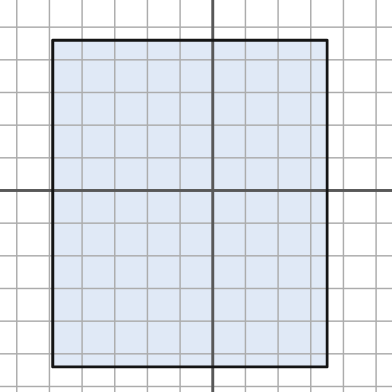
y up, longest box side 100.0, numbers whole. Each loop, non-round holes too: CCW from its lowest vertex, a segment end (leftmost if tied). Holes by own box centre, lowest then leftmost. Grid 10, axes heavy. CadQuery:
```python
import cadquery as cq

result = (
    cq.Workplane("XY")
    .moveTo(-49.0, -54.0)
    .lineTo(35.0, -54.0)
    .lineTo(35.0, 46.0)
    .lineTo(-49.0, 46.0)
    .close()
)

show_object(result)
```